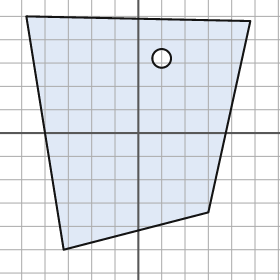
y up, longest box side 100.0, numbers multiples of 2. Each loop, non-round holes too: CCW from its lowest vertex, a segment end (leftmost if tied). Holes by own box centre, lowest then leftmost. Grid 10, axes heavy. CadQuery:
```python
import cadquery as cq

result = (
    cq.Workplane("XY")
    .moveTo(-32.0, -50.0)
    .lineTo(30.0, -34.0)
    .lineTo(48.0, 48.0)
    .lineTo(-48.0, 50.0)
    .close()
    .moveTo(10.0, 32.0)
    .circle(4.0)
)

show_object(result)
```